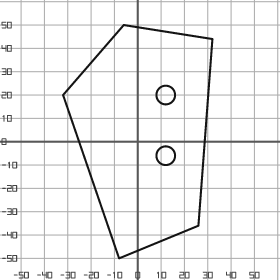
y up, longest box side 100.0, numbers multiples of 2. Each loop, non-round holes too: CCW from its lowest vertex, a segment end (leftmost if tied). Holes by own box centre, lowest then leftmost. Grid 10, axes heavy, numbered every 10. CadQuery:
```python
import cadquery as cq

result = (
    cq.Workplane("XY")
    .moveTo(-8.0, -50.0)
    .lineTo(26.0, -36.0)
    .lineTo(32.0, 44.0)
    .lineTo(-6.0, 50.0)
    .lineTo(-32.0, 20.0)
    .close()
    .moveTo(12.0, -6.0)
    .circle(4.0)
    .moveTo(12.0, 20.0)
    .circle(4.0)
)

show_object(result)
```